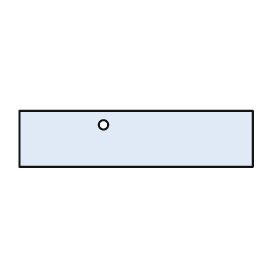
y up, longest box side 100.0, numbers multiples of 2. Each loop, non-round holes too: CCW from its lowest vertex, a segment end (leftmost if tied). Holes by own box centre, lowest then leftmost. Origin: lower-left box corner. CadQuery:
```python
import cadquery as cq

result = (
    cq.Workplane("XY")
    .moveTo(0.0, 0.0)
    .lineTo(100.0, 0.0)
    .lineTo(100.0, 24.0)
    .lineTo(0.0, 24.0)
    .close()
    .moveTo(36.0, 18.0)
    .circle(2.0)
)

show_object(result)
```